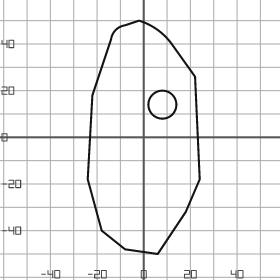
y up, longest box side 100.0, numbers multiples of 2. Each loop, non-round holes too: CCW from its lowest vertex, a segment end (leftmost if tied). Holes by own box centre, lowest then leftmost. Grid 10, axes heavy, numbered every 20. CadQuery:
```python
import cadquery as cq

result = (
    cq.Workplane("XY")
    .moveTo(6.0, -50.0)
    .lineTo(18.0, -32.0)
    .lineTo(24.0, -18.0)
    .lineTo(22.0, 26.0)
    .lineTo(12.0, 40.0)
    .threePointArc((6.0, 46.0), (-2.0, 50.0))
    .lineTo(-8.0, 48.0)
    .threePointArc((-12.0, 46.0), (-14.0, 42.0))
    .lineTo(-22.0, 18.0)
    .lineTo(-24.0, -18.0)
    .lineTo(-18.0, -40.0)
    .lineTo(-8.0, -48.0)
    .close()
    .moveTo(8.0, 14.0)
    .circle(6.0)
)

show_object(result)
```